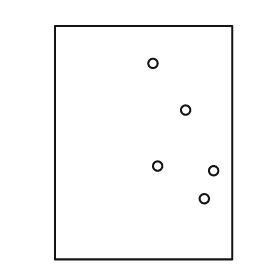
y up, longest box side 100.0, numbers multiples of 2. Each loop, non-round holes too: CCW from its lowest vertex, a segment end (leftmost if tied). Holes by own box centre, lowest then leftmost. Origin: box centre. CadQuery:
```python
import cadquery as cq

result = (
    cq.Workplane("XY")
    .moveTo(-38.0, -50.0)
    .lineTo(38.0, -50.0)
    .lineTo(38.0, 50.0)
    .lineTo(-38.0, 50.0)
    .close()
    .moveTo(26.0, -24.0)
    .circle(2.0)
    .moveTo(30.0, -12.0)
    .circle(2.0)
    .moveTo(6.0, -10.0)
    .circle(2.0)
    .moveTo(18.0, 14.0)
    .circle(2.0)
    .moveTo(4.0, 34.0)
    .circle(2.0)
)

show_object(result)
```